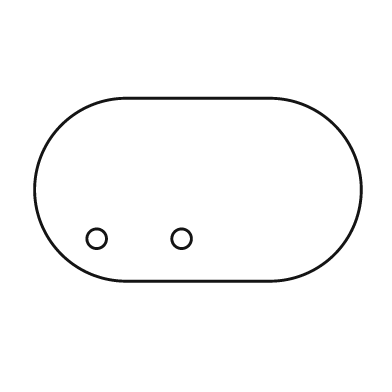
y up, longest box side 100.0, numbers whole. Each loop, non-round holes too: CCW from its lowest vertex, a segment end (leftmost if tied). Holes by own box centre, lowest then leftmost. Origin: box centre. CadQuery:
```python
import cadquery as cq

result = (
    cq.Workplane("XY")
    .moveTo(-22.0, -28.0)
    .lineTo(22.0, -28.0)
    .threePointArc((50.0, 0.0), (22.0, 28.0))
    .lineTo(-22.0, 28.0)
    .threePointArc((-50.0, 0.0), (-22.0, -28.0))
    .close()
    .moveTo(-31.0, -15.0)
    .circle(3.0)
    .moveTo(-5.0, -15.0)
    .circle(3.0)
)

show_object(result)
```